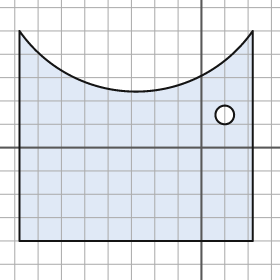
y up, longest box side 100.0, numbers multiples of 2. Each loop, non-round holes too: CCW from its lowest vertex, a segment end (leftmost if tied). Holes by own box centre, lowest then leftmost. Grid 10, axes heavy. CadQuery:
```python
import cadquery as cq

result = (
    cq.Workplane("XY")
    .moveTo(-78.0, -40.0)
    .lineTo(22.0, -40.0)
    .lineTo(22.0, 50.0)
    .threePointArc((-28.0, 24.0), (-78.0, 50.0))
    .close()
    .moveTo(10.0, 14.0)
    .circle(4.0)
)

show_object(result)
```